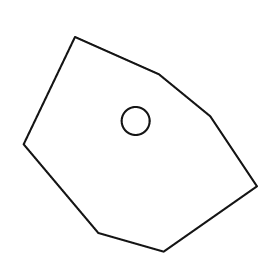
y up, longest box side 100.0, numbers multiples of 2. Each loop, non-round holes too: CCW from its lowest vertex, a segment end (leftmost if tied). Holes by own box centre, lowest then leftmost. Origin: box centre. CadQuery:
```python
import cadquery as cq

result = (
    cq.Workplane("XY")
    .moveTo(10.0, -46.0)
    .lineTo(50.0, -18.0)
    .lineTo(30.0, 12.0)
    .lineTo(8.0, 30.0)
    .lineTo(-28.0, 46.0)
    .lineTo(-50.0, 0.0)
    .lineTo(-18.0, -38.0)
    .close()
    .moveTo(-2.0, 10.0)
    .circle(6.0)
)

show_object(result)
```